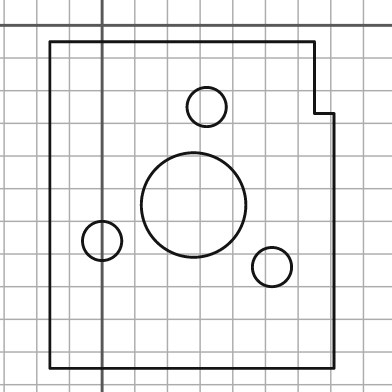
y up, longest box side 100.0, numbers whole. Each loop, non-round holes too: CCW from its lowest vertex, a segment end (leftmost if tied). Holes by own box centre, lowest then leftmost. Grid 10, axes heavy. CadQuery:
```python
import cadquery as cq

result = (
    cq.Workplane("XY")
    .moveTo(-16.0, -105.0)
    .lineTo(71.0, -105.0)
    .lineTo(71.0, -27.0)
    .lineTo(65.0, -27.0)
    .lineTo(65.0, -5.0)
    .lineTo(-16.0, -5.0)
    .close()
    .moveTo(52.0, -74.0)
    .circle(6.0)
    .moveTo(0.0, -66.0)
    .circle(6.0)
    .moveTo(28.0, -55.0)
    .circle(16.0)
    .moveTo(32.0, -25.0)
    .circle(6.0)
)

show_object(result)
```